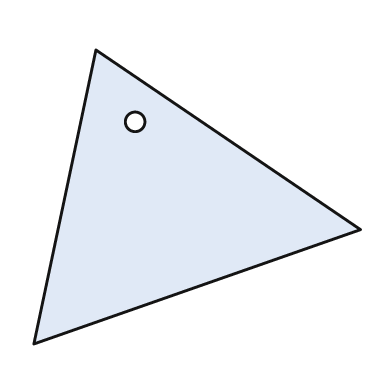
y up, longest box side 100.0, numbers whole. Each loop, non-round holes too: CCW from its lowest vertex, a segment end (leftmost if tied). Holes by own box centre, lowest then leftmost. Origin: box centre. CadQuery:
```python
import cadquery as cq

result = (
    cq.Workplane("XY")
    .moveTo(-50.0, -45.0)
    .lineTo(50.0, -10.0)
    .lineTo(-31.0, 45.0)
    .close()
    .moveTo(-19.0, 23.0)
    .circle(3.0)
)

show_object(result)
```